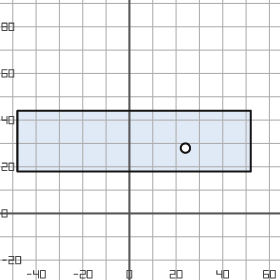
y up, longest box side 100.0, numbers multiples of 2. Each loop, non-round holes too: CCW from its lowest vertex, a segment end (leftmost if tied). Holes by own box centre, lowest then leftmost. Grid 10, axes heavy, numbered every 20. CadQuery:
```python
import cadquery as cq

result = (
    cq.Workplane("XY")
    .moveTo(-48.0, 18.0)
    .lineTo(52.0, 18.0)
    .lineTo(52.0, 44.0)
    .lineTo(-48.0, 44.0)
    .close()
    .moveTo(24.0, 28.0)
    .circle(2.0)
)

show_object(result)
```